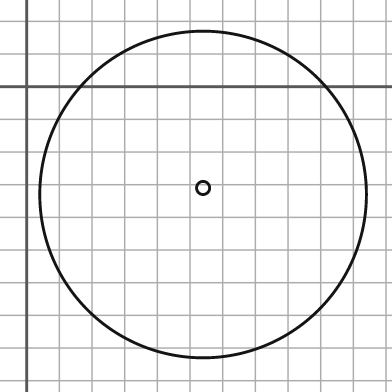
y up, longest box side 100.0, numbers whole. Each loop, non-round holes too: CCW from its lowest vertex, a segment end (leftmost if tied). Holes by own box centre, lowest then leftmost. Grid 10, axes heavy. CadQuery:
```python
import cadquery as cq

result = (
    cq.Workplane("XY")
    .moveTo(54.0, -33.0)
    .circle(50.0)
    .moveTo(54.0, -31.0)
    .circle(2.0)
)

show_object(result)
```